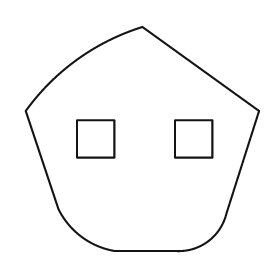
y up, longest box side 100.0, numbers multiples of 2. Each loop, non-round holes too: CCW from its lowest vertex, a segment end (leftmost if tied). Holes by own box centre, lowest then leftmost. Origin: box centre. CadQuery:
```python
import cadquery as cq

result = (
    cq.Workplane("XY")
    .moveTo(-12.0, -48.0)
    .lineTo(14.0, -48.0)
    .threePointArc((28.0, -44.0), (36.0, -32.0))
    .lineTo(50.0, 12.0)
    .lineTo(0.0, 48.0)
    .threePointArc((-28.0, 34.0), (-50.0, 12.0))
    .lineTo(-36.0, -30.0)
    .threePointArc((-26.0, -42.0), (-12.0, -48.0))
    .close()
    .moveTo(-28.0, -8.0)
    .lineTo(-12.0, -8.0)
    .lineTo(-12.0, 8.0)
    .lineTo(-28.0, 8.0)
    .close()
    .moveTo(14.0, -8.0)
    .lineTo(30.0, -8.0)
    .lineTo(30.0, 8.0)
    .lineTo(14.0, 8.0)
    .close()
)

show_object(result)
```